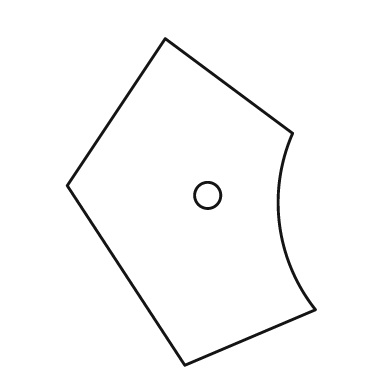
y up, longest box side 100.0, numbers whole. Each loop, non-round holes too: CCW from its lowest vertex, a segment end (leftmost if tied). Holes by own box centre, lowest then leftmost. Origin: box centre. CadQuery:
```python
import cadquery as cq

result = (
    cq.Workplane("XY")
    .moveTo(-2.0, -50.0)
    .lineTo(38.0, -33.0)
    .threePointArc((27.0, -7.0), (31.0, 21.0))
    .lineTo(-8.0, 50.0)
    .lineTo(-38.0, 5.0)
    .close()
    .moveTo(5.0, 2.0)
    .circle(4.0)
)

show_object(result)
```